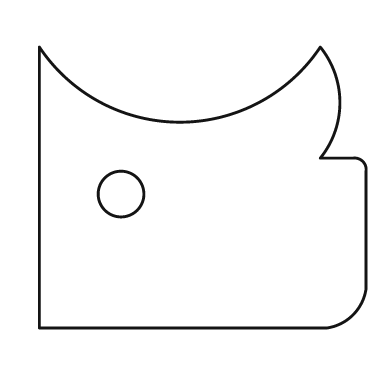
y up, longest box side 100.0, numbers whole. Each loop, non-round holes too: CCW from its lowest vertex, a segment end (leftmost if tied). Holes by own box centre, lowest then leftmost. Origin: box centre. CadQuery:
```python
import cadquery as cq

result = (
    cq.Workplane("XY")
    .moveTo(-50.0, -43.0)
    .lineTo(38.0, -43.0)
    .threePointArc((46.0, -39.0), (50.0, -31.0))
    .lineTo(50.0, 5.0)
    .threePointArc((49.0, 8.0), (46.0, 9.0))
    .lineTo(36.0, 9.0)
    .threePointArc((42.0, 26.0), (36.0, 43.0))
    .threePointArc((-7.0, 20.0), (-50.0, 43.0))
    .close()
    .moveTo(-25.0, -2.0)
    .circle(7.0)
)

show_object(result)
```